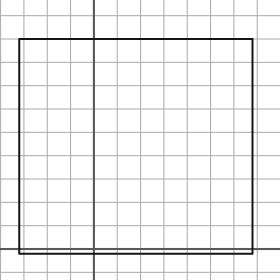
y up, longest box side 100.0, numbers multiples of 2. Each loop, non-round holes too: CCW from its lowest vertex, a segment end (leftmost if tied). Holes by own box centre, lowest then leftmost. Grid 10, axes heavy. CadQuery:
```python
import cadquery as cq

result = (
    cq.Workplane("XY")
    .moveTo(-32.0, -2.0)
    .lineTo(68.0, -2.0)
    .lineTo(68.0, 90.0)
    .lineTo(-32.0, 90.0)
    .close()
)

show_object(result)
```